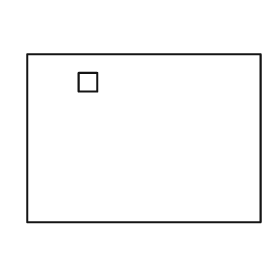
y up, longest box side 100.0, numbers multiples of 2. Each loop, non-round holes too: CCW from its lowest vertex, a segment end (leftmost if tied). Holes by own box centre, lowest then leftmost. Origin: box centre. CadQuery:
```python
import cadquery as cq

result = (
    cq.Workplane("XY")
    .moveTo(-50.0, -36.0)
    .lineTo(50.0, -36.0)
    .lineTo(50.0, 36.0)
    .lineTo(-50.0, 36.0)
    .close()
    .moveTo(-28.0, 20.0)
    .lineTo(-20.0, 20.0)
    .lineTo(-20.0, 28.0)
    .lineTo(-28.0, 28.0)
    .close()
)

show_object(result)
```